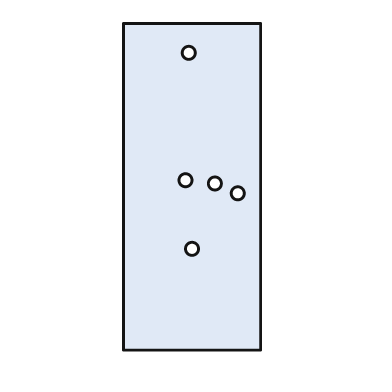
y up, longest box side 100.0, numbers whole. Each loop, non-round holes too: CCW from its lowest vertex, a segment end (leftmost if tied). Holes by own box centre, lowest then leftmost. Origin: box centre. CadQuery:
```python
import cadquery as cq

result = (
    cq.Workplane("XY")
    .moveTo(-21.0, -50.0)
    .lineTo(21.0, -50.0)
    .lineTo(21.0, 50.0)
    .lineTo(-21.0, 50.0)
    .close()
    .moveTo(0.0, -19.0)
    .circle(2.0)
    .moveTo(14.0, -2.0)
    .circle(2.0)
    .moveTo(7.0, 1.0)
    .circle(2.0)
    .moveTo(-2.0, 2.0)
    .circle(2.0)
    .moveTo(-1.0, 41.0)
    .circle(2.0)
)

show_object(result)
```